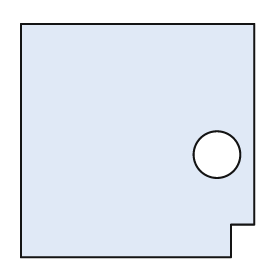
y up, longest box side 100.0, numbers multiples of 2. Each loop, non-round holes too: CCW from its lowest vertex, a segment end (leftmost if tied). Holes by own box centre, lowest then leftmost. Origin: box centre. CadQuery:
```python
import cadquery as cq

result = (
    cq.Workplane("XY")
    .moveTo(-50.0, -50.0)
    .lineTo(40.0, -50.0)
    .lineTo(40.0, -36.0)
    .lineTo(50.0, -36.0)
    .lineTo(50.0, 50.0)
    .lineTo(-50.0, 50.0)
    .close()
    .moveTo(34.0, -6.0)
    .circle(10.0)
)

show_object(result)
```